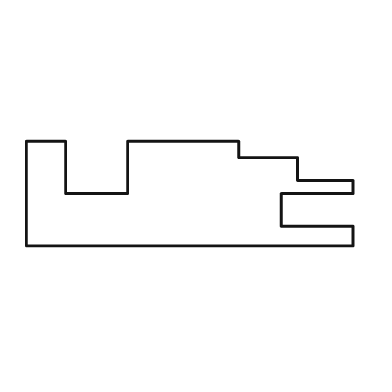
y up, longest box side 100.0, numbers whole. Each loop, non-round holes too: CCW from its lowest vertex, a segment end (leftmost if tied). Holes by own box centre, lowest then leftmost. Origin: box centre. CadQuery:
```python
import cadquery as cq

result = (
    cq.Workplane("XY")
    .moveTo(-50.0, -16.0)
    .lineTo(50.0, -16.0)
    .lineTo(50.0, -10.0)
    .lineTo(28.0, -10.0)
    .lineTo(28.0, 0.0)
    .lineTo(50.0, 0.0)
    .lineTo(50.0, 4.0)
    .lineTo(33.0, 4.0)
    .lineTo(33.0, 11.0)
    .lineTo(15.0, 11.0)
    .lineTo(15.0, 16.0)
    .lineTo(-19.0, 16.0)
    .lineTo(-19.0, 0.0)
    .lineTo(-38.0, 0.0)
    .lineTo(-38.0, 16.0)
    .lineTo(-50.0, 16.0)
    .close()
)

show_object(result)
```